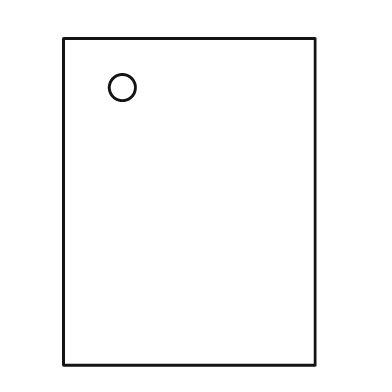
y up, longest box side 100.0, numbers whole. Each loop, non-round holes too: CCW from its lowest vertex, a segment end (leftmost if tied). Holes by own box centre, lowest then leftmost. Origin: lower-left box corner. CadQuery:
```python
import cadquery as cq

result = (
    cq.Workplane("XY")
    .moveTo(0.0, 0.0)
    .lineTo(77.0, 0.0)
    .lineTo(77.0, 100.0)
    .lineTo(0.0, 100.0)
    .close()
    .moveTo(18.0, 85.0)
    .circle(4.0)
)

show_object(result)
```